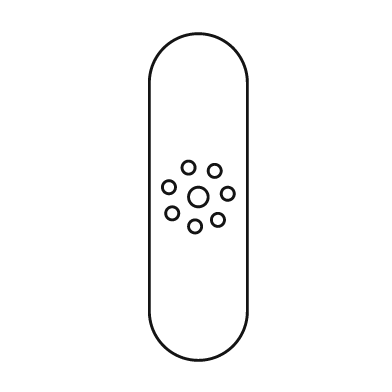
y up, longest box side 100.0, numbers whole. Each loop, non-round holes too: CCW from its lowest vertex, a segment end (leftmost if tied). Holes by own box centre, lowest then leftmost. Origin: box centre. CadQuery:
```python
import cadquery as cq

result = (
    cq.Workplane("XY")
    .moveTo(-15.0, -35.0)
    .threePointArc((0.0, -50.0), (15.0, -35.0))
    .lineTo(15.0, 35.0)
    .threePointArc((0.0, 50.0), (-15.0, 35.0))
    .close()
    .moveTo(-1.0, -9.0)
    .circle(2.0)
    .moveTo(6.0, -7.0)
    .circle(2.0)
    .moveTo(-8.0, -5.0)
    .circle(2.0)
    .moveTo(0.0, 0.0)
    .circle(3.0)
    .moveTo(9.0, 1.0)
    .circle(2.0)
    .moveTo(-9.0, 3.0)
    .circle(2.0)
    .moveTo(5.0, 8.0)
    .circle(2.0)
    .moveTo(-3.0, 9.0)
    .circle(2.0)
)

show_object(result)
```